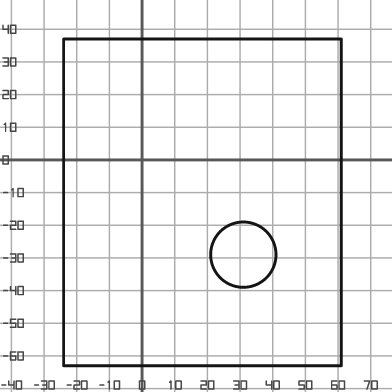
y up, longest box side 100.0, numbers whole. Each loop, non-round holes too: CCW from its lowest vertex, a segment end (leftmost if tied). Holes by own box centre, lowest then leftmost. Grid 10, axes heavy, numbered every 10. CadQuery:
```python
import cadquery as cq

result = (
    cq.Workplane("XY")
    .moveTo(-24.0, -63.0)
    .lineTo(61.0, -63.0)
    .lineTo(61.0, 37.0)
    .lineTo(-24.0, 37.0)
    .close()
    .moveTo(31.0, -29.0)
    .circle(10.0)
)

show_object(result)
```